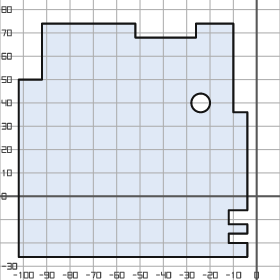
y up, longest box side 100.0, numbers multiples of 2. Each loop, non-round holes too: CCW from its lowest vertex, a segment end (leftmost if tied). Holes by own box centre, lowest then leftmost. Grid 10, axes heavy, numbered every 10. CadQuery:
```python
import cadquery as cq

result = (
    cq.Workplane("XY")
    .moveTo(-102.0, -26.0)
    .lineTo(-4.0, -26.0)
    .lineTo(-4.0, -20.0)
    .lineTo(-12.0, -20.0)
    .lineTo(-12.0, -16.0)
    .lineTo(-4.0, -16.0)
    .lineTo(-4.0, -12.0)
    .lineTo(-12.0, -12.0)
    .lineTo(-12.0, -6.0)
    .lineTo(-4.0, -6.0)
    .lineTo(-4.0, 36.0)
    .lineTo(-10.0, 36.0)
    .lineTo(-10.0, 74.0)
    .lineTo(-26.0, 74.0)
    .lineTo(-26.0, 68.0)
    .lineTo(-52.0, 68.0)
    .lineTo(-52.0, 74.0)
    .lineTo(-92.0, 74.0)
    .lineTo(-92.0, 50.0)
    .lineTo(-102.0, 50.0)
    .close()
    .moveTo(-24.0, 40.0)
    .circle(4.0)
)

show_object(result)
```